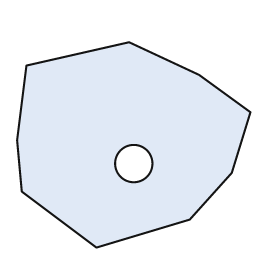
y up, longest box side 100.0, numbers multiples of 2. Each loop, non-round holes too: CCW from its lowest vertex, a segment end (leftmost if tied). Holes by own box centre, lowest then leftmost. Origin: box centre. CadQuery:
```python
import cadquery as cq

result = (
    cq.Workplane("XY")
    .moveTo(-16.0, -44.0)
    .lineTo(24.0, -32.0)
    .lineTo(42.0, -12.0)
    .lineTo(50.0, 14.0)
    .lineTo(28.0, 30.0)
    .lineTo(-2.0, 44.0)
    .lineTo(-46.0, 34.0)
    .lineTo(-50.0, 2.0)
    .lineTo(-48.0, -20.0)
    .close()
    .moveTo(0.0, -8.0)
    .circle(8.0)
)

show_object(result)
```